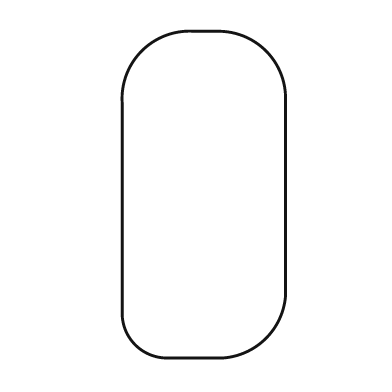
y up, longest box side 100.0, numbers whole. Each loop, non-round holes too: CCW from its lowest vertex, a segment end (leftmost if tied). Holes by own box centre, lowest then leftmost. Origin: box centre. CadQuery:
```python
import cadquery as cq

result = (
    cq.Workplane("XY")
    .moveTo(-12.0, -50.0)
    .lineTo(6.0, -50.0)
    .threePointArc((19.0, -44.0), (25.0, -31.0))
    .lineTo(25.0, 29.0)
    .threePointArc((19.0, 44.0), (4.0, 50.0))
    .lineTo(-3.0, 50.0)
    .threePointArc((-19.0, 44.0), (-25.0, 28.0))
    .lineTo(-25.0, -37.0)
    .threePointArc((-21.0, -46.0), (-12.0, -50.0))
    .close()
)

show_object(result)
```